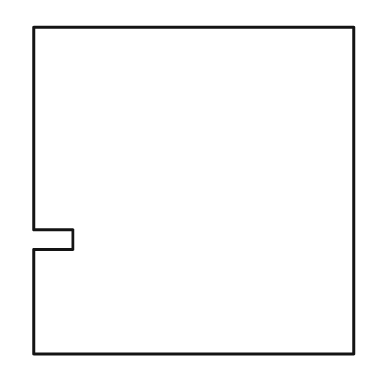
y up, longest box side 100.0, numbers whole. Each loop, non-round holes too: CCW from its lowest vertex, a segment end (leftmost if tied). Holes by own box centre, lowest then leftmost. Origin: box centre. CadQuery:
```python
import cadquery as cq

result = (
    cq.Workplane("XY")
    .moveTo(-49.0, -50.0)
    .lineTo(49.0, -50.0)
    .lineTo(49.0, 50.0)
    .lineTo(-49.0, 50.0)
    .lineTo(-49.0, -12.0)
    .lineTo(-37.0, -12.0)
    .lineTo(-37.0, -18.0)
    .lineTo(-49.0, -18.0)
    .close()
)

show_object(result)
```